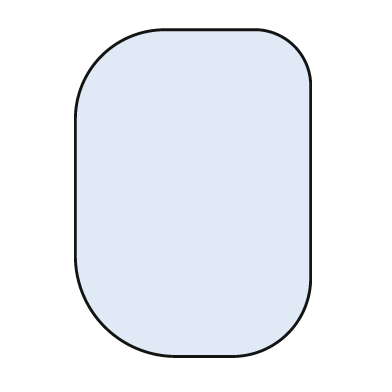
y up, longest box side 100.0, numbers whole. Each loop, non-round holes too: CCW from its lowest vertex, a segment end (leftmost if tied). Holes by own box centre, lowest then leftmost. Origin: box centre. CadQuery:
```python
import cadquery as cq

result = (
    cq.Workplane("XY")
    .moveTo(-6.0, -50.0)
    .lineTo(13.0, -50.0)
    .threePointArc((29.0, -43.0), (36.0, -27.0))
    .lineTo(36.0, 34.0)
    .threePointArc((31.0, 45.0), (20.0, 50.0))
    .lineTo(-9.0, 50.0)
    .threePointArc((-28.0, 42.0), (-36.0, 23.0))
    .lineTo(-36.0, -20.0)
    .threePointArc((-27.0, -41.0), (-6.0, -50.0))
    .close()
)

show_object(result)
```